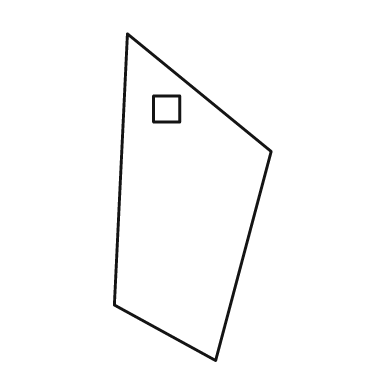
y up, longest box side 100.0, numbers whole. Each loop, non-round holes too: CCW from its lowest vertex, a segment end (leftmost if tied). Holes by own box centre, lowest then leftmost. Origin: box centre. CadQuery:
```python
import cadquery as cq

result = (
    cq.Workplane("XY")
    .moveTo(7.0, -50.0)
    .lineTo(24.0, 14.0)
    .lineTo(-20.0, 50.0)
    .lineTo(-24.0, -33.0)
    .close()
    .moveTo(-12.0, 23.0)
    .lineTo(-4.0, 23.0)
    .lineTo(-4.0, 31.0)
    .lineTo(-12.0, 31.0)
    .close()
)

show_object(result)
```